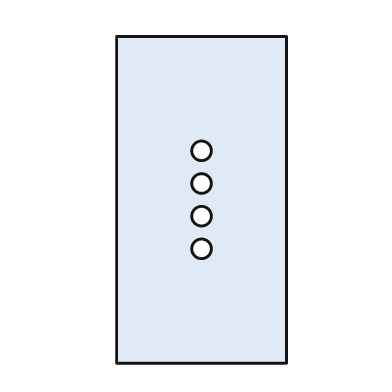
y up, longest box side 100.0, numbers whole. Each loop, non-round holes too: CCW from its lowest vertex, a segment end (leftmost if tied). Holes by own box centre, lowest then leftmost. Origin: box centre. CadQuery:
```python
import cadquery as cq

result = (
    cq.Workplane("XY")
    .moveTo(-26.0, -50.0)
    .lineTo(26.0, -50.0)
    .lineTo(26.0, 50.0)
    .lineTo(-26.0, 50.0)
    .close()
    .moveTo(0.0, -15.0)
    .circle(3.0)
    .moveTo(0.0, -5.0)
    .circle(3.0)
    .moveTo(0.0, 5.0)
    .circle(3.0)
    .moveTo(0.0, 15.0)
    .circle(3.0)
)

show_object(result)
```